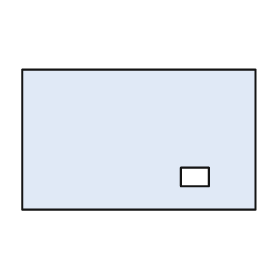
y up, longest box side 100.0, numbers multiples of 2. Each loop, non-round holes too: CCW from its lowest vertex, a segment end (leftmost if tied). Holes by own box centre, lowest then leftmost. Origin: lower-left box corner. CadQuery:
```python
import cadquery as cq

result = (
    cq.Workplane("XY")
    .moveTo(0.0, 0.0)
    .lineTo(100.0, 0.0)
    .lineTo(100.0, 60.0)
    .lineTo(0.0, 60.0)
    .close()
    .moveTo(68.0, 10.0)
    .lineTo(80.0, 10.0)
    .lineTo(80.0, 18.0)
    .lineTo(68.0, 18.0)
    .close()
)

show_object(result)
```